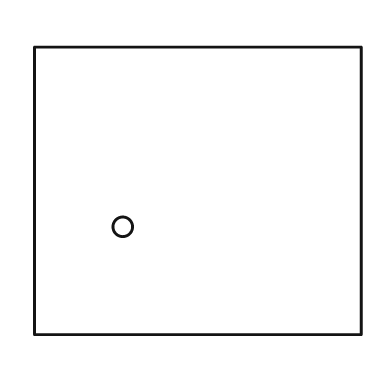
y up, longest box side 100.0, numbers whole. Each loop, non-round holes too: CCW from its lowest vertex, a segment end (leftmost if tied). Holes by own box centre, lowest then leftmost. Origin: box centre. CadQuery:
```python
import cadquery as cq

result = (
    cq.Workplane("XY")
    .moveTo(-50.0, -44.0)
    .lineTo(50.0, -44.0)
    .lineTo(50.0, 44.0)
    .lineTo(-50.0, 44.0)
    .close()
    .moveTo(-23.0, -11.0)
    .circle(3.0)
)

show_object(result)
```